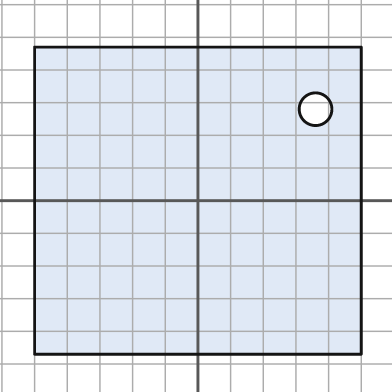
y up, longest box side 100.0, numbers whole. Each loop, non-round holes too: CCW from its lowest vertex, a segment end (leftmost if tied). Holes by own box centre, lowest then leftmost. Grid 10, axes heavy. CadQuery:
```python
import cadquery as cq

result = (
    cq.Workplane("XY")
    .moveTo(-50.0, -47.0)
    .lineTo(50.0, -47.0)
    .lineTo(50.0, 47.0)
    .lineTo(-50.0, 47.0)
    .close()
    .moveTo(36.0, 28.0)
    .circle(5.0)
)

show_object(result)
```